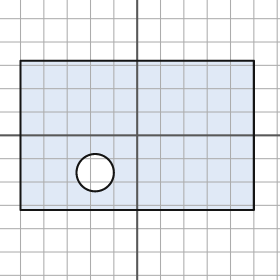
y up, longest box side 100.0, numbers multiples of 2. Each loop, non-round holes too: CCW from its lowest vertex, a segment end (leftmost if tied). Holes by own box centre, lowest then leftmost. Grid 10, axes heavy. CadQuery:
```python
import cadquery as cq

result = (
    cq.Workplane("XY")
    .moveTo(-50.0, -32.0)
    .lineTo(50.0, -32.0)
    .lineTo(50.0, 32.0)
    .lineTo(-50.0, 32.0)
    .close()
    .moveTo(-18.0, -16.0)
    .circle(8.0)
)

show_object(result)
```